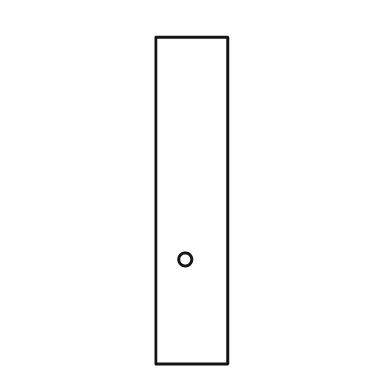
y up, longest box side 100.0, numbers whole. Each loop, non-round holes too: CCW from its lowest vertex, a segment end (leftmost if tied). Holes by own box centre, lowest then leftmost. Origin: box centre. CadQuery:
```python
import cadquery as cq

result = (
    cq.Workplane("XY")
    .moveTo(-11.0, -50.0)
    .lineTo(11.0, -50.0)
    .lineTo(11.0, 50.0)
    .lineTo(-11.0, 50.0)
    .close()
    .moveTo(-2.0, -18.0)
    .circle(2.0)
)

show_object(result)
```